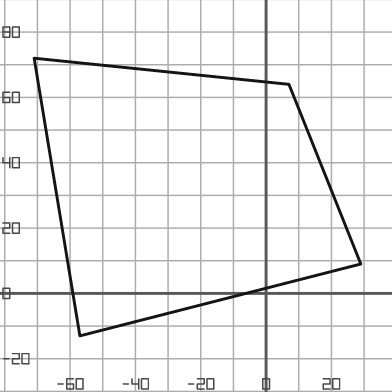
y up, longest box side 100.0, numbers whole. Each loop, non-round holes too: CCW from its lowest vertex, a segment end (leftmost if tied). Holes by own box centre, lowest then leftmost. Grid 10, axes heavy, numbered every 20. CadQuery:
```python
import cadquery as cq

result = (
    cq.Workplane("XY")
    .moveTo(-57.0, -13.0)
    .lineTo(29.0, 9.0)
    .lineTo(7.0, 64.0)
    .lineTo(-71.0, 72.0)
    .close()
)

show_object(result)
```